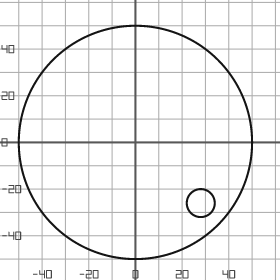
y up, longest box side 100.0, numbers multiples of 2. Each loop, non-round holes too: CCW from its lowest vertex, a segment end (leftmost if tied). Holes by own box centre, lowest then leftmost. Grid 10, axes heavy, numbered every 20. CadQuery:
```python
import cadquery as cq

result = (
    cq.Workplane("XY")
    .moveTo(0.0, 0.0)
    .circle(50.0)
    .moveTo(28.0, -26.0)
    .circle(6.0)
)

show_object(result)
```